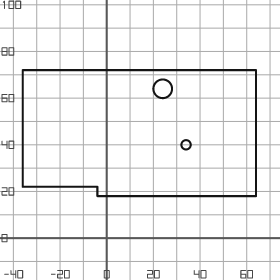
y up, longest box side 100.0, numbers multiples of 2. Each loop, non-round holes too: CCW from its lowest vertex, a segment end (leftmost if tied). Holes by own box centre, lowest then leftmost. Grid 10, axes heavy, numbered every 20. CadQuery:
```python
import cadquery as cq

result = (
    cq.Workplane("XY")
    .moveTo(-4.0, 18.0)
    .lineTo(64.0, 18.0)
    .lineTo(64.0, 72.0)
    .lineTo(-36.0, 72.0)
    .lineTo(-36.0, 22.0)
    .lineTo(-4.0, 22.0)
    .close()
    .moveTo(34.0, 40.0)
    .circle(2.0)
    .moveTo(24.0, 64.0)
    .circle(4.0)
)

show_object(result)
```